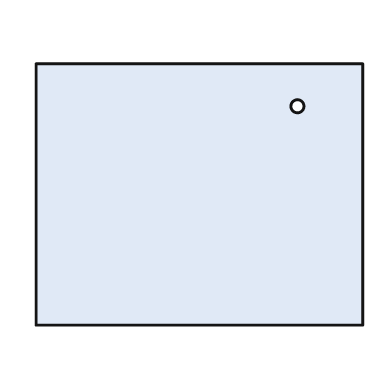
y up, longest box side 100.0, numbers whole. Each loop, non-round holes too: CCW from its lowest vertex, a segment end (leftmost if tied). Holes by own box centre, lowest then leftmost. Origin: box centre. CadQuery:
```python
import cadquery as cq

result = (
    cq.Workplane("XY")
    .moveTo(-50.0, -40.0)
    .lineTo(50.0, -40.0)
    .lineTo(50.0, 40.0)
    .lineTo(-50.0, 40.0)
    .close()
    .moveTo(30.0, 27.0)
    .circle(2.0)
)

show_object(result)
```